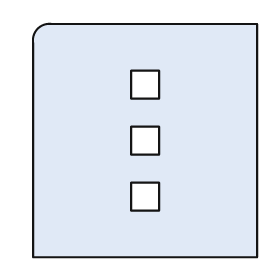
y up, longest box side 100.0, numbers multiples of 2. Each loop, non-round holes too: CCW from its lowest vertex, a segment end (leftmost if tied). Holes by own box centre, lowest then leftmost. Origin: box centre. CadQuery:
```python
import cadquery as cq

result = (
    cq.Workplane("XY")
    .moveTo(-48.0, -50.0)
    .lineTo(48.0, -50.0)
    .lineTo(48.0, 50.0)
    .lineTo(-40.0, 50.0)
    .threePointArc((-46.0, 48.0), (-48.0, 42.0))
    .close()
    .moveTo(-6.0, -30.0)
    .lineTo(6.0, -30.0)
    .lineTo(6.0, -18.0)
    .lineTo(-6.0, -18.0)
    .close()
    .moveTo(-6.0, -6.0)
    .lineTo(6.0, -6.0)
    .lineTo(6.0, 6.0)
    .lineTo(-6.0, 6.0)
    .close()
    .moveTo(-6.0, 18.0)
    .lineTo(6.0, 18.0)
    .lineTo(6.0, 30.0)
    .lineTo(-6.0, 30.0)
    .close()
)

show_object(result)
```